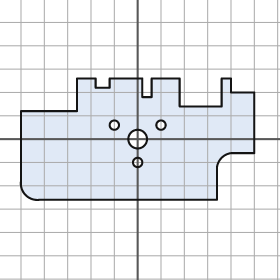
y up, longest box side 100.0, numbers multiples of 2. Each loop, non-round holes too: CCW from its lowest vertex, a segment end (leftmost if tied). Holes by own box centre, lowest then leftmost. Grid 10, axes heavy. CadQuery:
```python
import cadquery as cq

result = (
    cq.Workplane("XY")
    .moveTo(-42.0, -26.0)
    .lineTo(34.0, -26.0)
    .lineTo(34.0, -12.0)
    .threePointArc((36.0, -8.0), (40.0, -6.0))
    .lineTo(50.0, -6.0)
    .lineTo(50.0, 20.0)
    .lineTo(40.0, 20.0)
    .lineTo(40.0, 26.0)
    .lineTo(36.0, 26.0)
    .lineTo(36.0, 14.0)
    .lineTo(18.0, 14.0)
    .lineTo(18.0, 26.0)
    .lineTo(6.0, 26.0)
    .lineTo(6.0, 18.0)
    .lineTo(2.0, 18.0)
    .lineTo(2.0, 26.0)
    .lineTo(-12.0, 26.0)
    .lineTo(-12.0, 22.0)
    .lineTo(-18.0, 22.0)
    .lineTo(-18.0, 26.0)
    .lineTo(-26.0, 26.0)
    .lineTo(-26.0, 12.0)
    .lineTo(-50.0, 12.0)
    .lineTo(-50.0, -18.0)
    .threePointArc((-48.0, -24.0), (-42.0, -26.0))
    .close()
    .moveTo(0.0, -10.0)
    .circle(2.0)
    .moveTo(0.0, 0.0)
    .circle(4.0)
    .moveTo(-10.0, 6.0)
    .circle(2.0)
    .moveTo(10.0, 6.0)
    .circle(2.0)
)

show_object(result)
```